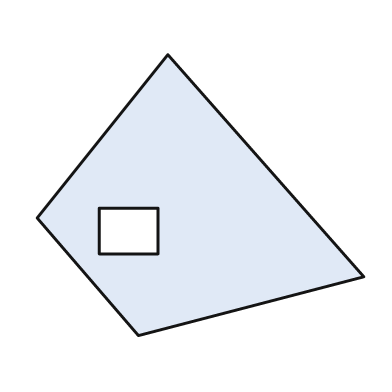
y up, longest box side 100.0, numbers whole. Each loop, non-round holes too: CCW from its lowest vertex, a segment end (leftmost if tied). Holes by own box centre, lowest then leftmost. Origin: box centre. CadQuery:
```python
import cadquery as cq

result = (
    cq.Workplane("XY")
    .moveTo(-19.0, -43.0)
    .lineTo(50.0, -25.0)
    .lineTo(-10.0, 43.0)
    .lineTo(-50.0, -7.0)
    .close()
    .moveTo(-31.0, -18.0)
    .lineTo(-13.0, -18.0)
    .lineTo(-13.0, -4.0)
    .lineTo(-31.0, -4.0)
    .close()
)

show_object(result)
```